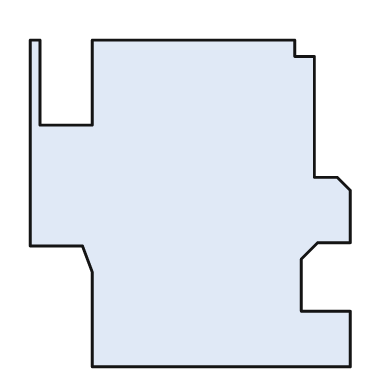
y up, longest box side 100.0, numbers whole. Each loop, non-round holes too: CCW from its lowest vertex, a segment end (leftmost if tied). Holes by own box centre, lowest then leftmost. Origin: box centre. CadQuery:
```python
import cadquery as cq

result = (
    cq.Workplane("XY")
    .moveTo(-30.0, -50.0)
    .lineTo(49.0, -50.0)
    .lineTo(49.0, -33.0)
    .lineTo(34.0, -33.0)
    .lineTo(34.0, -17.0)
    .lineTo(39.0, -12.0)
    .lineTo(49.0, -12.0)
    .lineTo(49.0, 4.0)
    .lineTo(45.0, 8.0)
    .lineTo(38.0, 8.0)
    .lineTo(38.0, 45.0)
    .lineTo(32.0, 45.0)
    .lineTo(32.0, 50.0)
    .lineTo(-30.0, 50.0)
    .lineTo(-30.0, 24.0)
    .lineTo(-46.0, 24.0)
    .lineTo(-46.0, 50.0)
    .lineTo(-49.0, 50.0)
    .lineTo(-49.0, -13.0)
    .lineTo(-33.0, -13.0)
    .lineTo(-30.0, -21.0)
    .close()
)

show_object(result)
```